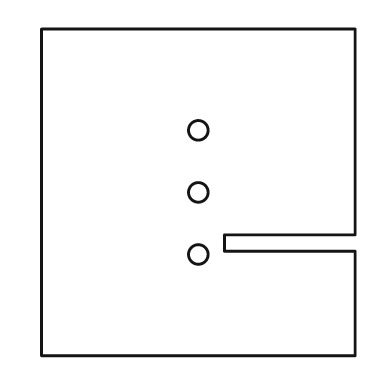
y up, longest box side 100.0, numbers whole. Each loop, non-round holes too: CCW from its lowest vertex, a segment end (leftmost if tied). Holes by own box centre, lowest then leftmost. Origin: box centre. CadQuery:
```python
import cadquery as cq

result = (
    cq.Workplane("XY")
    .moveTo(-48.0, -50.0)
    .lineTo(48.0, -50.0)
    .lineTo(48.0, -18.0)
    .lineTo(8.0, -18.0)
    .lineTo(8.0, -13.0)
    .lineTo(48.0, -13.0)
    .lineTo(48.0, 50.0)
    .lineTo(-48.0, 50.0)
    .close()
    .moveTo(0.0, -19.0)
    .circle(3.0)
    .moveTo(0.0, 0.0)
    .circle(3.0)
    .moveTo(0.0, 19.0)
    .circle(3.0)
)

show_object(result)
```